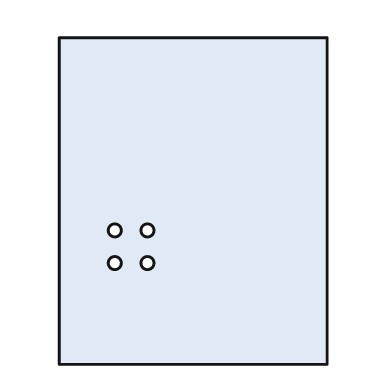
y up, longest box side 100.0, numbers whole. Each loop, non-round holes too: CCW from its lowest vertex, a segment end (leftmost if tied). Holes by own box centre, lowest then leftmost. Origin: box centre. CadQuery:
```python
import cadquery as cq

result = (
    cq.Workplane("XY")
    .moveTo(-41.0, -50.0)
    .lineTo(41.0, -50.0)
    .lineTo(41.0, 50.0)
    .lineTo(-41.0, 50.0)
    .close()
    .moveTo(-24.0, -19.0)
    .circle(2.0)
    .moveTo(-14.0, -19.0)
    .circle(2.0)
    .moveTo(-24.0, -9.0)
    .circle(2.0)
    .moveTo(-14.0, -9.0)
    .circle(2.0)
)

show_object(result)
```